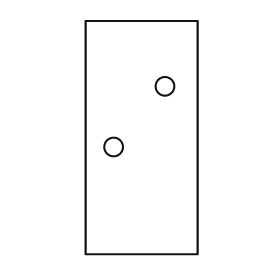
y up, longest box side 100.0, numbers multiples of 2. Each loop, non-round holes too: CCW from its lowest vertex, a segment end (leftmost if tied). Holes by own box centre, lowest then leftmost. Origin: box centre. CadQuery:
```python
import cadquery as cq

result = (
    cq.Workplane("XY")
    .moveTo(-24.0, -50.0)
    .lineTo(24.0, -50.0)
    .lineTo(24.0, 50.0)
    .lineTo(-24.0, 50.0)
    .close()
    .moveTo(-12.0, -4.0)
    .circle(4.0)
    .moveTo(10.0, 22.0)
    .circle(4.0)
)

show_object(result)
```